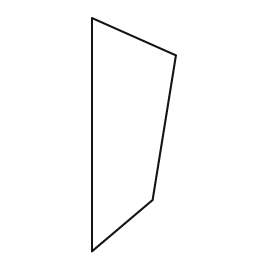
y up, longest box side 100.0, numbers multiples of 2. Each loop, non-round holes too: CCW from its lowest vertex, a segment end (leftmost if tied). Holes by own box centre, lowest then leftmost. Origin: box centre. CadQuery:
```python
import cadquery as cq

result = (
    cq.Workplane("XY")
    .moveTo(-18.0, -50.0)
    .lineTo(8.0, -28.0)
    .lineTo(18.0, 34.0)
    .lineTo(-18.0, 50.0)
    .close()
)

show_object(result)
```